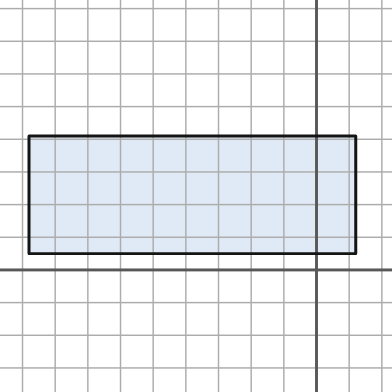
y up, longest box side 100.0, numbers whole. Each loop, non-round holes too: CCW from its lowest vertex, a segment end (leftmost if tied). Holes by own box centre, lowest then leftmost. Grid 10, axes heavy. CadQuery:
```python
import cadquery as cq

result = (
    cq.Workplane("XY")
    .moveTo(-88.0, 5.0)
    .lineTo(12.0, 5.0)
    .lineTo(12.0, 41.0)
    .lineTo(-88.0, 41.0)
    .close()
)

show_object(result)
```